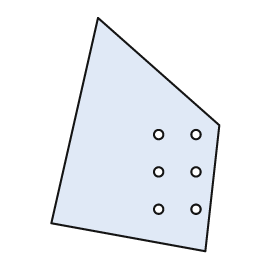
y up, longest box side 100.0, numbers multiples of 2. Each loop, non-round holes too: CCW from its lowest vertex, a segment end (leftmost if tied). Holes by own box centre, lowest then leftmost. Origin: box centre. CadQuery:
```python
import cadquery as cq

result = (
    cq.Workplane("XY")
    .moveTo(30.0, -50.0)
    .lineTo(36.0, 4.0)
    .lineTo(-16.0, 50.0)
    .lineTo(-36.0, -38.0)
    .close()
    .moveTo(10.0, -32.0)
    .circle(2.0)
    .moveTo(26.0, -32.0)
    .circle(2.0)
    .moveTo(10.0, -16.0)
    .circle(2.0)
    .moveTo(26.0, -16.0)
    .circle(2.0)
    .moveTo(10.0, 0.0)
    .circle(2.0)
    .moveTo(26.0, 0.0)
    .circle(2.0)
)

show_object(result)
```